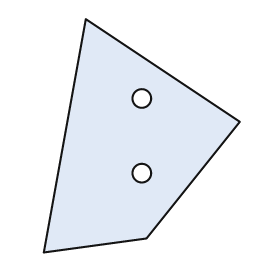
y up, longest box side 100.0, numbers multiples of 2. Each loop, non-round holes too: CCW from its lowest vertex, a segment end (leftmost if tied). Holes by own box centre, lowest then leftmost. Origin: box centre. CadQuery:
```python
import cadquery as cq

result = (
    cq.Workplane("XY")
    .moveTo(-42.0, -50.0)
    .lineTo(2.0, -44.0)
    .lineTo(42.0, 6.0)
    .lineTo(-24.0, 50.0)
    .close()
    .moveTo(0.0, -16.0)
    .circle(4.0)
    .moveTo(0.0, 16.0)
    .circle(4.0)
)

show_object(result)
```